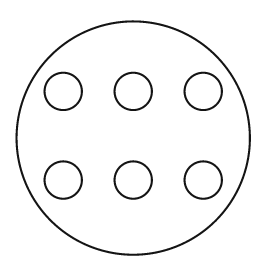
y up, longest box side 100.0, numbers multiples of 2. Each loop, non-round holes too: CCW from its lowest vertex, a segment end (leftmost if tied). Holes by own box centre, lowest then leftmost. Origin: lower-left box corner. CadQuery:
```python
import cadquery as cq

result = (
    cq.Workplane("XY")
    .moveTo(50.0, 50.0)
    .circle(50.0)
    .moveTo(20.0, 32.0)
    .circle(8.0)
    .moveTo(50.0, 32.0)
    .circle(8.0)
    .moveTo(80.0, 32.0)
    .circle(8.0)
    .moveTo(20.0, 70.0)
    .circle(8.0)
    .moveTo(50.0, 70.0)
    .circle(8.0)
    .moveTo(80.0, 70.0)
    .circle(8.0)
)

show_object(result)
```